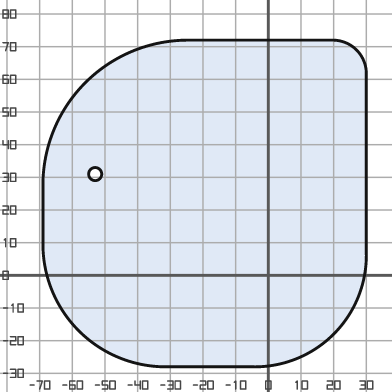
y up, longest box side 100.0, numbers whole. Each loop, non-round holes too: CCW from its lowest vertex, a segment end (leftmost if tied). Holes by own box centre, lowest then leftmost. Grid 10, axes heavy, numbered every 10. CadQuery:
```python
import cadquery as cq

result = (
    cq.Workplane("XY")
    .moveTo(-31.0, -28.0)
    .lineTo(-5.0, -28.0)
    .threePointArc((20.0, -18.0), (30.0, 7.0))
    .lineTo(30.0, 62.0)
    .threePointArc((27.0, 69.0), (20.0, 72.0))
    .lineTo(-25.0, 72.0)
    .threePointArc((-56.0, 59.0), (-69.0, 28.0))
    .lineTo(-69.0, 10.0)
    .threePointArc((-58.0, -17.0), (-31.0, -28.0))
    .close()
    .moveTo(-53.0, 31.0)
    .circle(2.0)
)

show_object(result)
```